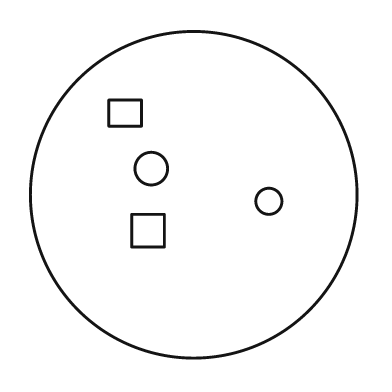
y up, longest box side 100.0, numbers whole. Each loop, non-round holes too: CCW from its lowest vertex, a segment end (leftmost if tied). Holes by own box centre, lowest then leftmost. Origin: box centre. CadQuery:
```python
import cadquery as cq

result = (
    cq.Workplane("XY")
    .moveTo(0.0, 0.0)
    .circle(50.0)
    .moveTo(-19.0, -16.0)
    .lineTo(-9.0, -16.0)
    .lineTo(-9.0, -6.0)
    .lineTo(-19.0, -6.0)
    .close()
    .moveTo(23.0, -2.0)
    .circle(4.0)
    .moveTo(-13.0, 8.0)
    .circle(5.0)
    .moveTo(-26.0, 21.0)
    .lineTo(-16.0, 21.0)
    .lineTo(-16.0, 29.0)
    .lineTo(-26.0, 29.0)
    .close()
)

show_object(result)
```